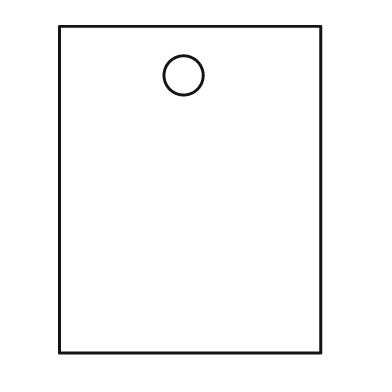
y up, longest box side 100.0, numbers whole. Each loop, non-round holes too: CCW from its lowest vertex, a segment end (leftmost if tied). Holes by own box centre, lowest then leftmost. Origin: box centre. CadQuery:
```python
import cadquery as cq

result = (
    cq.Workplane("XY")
    .moveTo(-40.0, -50.0)
    .lineTo(40.0, -50.0)
    .lineTo(40.0, 50.0)
    .lineTo(-40.0, 50.0)
    .close()
    .moveTo(-2.0, 35.0)
    .circle(6.0)
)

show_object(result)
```